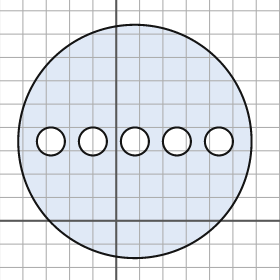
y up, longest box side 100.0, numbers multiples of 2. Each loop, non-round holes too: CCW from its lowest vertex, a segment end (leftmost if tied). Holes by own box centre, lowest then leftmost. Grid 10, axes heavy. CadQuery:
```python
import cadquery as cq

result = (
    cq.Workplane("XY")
    .moveTo(8.0, 34.0)
    .circle(50.0)
    .moveTo(-28.0, 34.0)
    .circle(6.0)
    .moveTo(-10.0, 34.0)
    .circle(6.0)
    .moveTo(8.0, 34.0)
    .circle(6.0)
    .moveTo(26.0, 34.0)
    .circle(6.0)
    .moveTo(44.0, 34.0)
    .circle(6.0)
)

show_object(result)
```